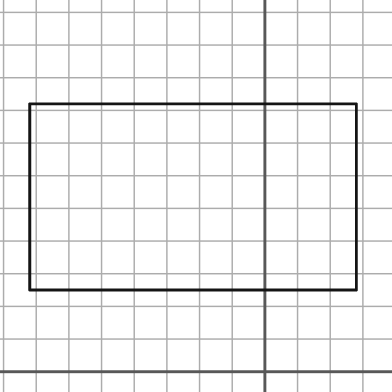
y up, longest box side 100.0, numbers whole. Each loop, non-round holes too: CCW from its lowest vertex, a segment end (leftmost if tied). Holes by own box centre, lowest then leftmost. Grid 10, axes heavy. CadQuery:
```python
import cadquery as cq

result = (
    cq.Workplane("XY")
    .moveTo(-72.0, 25.0)
    .lineTo(28.0, 25.0)
    .lineTo(28.0, 82.0)
    .lineTo(-72.0, 82.0)
    .close()
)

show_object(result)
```